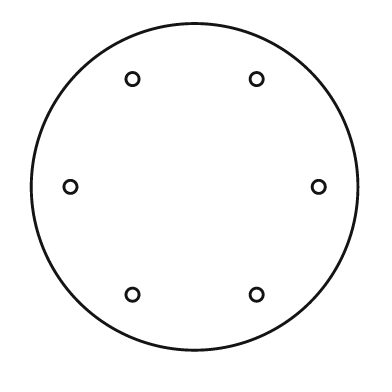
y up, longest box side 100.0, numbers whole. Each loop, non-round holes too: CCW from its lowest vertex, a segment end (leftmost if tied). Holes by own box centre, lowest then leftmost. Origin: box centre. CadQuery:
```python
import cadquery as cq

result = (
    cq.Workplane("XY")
    .moveTo(0.0, 0.0)
    .circle(50.0)
    .moveTo(-19.0, -33.0)
    .circle(2.0)
    .moveTo(19.0, -33.0)
    .circle(2.0)
    .moveTo(-38.0, 0.0)
    .circle(2.0)
    .moveTo(38.0, 0.0)
    .circle(2.0)
    .moveTo(-19.0, 33.0)
    .circle(2.0)
    .moveTo(19.0, 33.0)
    .circle(2.0)
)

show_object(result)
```